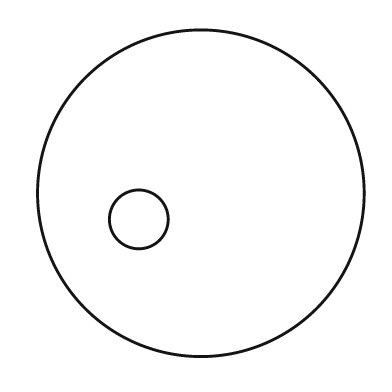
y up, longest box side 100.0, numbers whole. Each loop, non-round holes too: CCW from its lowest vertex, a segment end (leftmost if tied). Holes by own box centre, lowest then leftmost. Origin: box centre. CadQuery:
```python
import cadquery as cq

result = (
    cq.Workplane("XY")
    .moveTo(0.0, 0.0)
    .circle(50.0)
    .moveTo(-19.0, -8.0)
    .circle(9.0)
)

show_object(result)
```